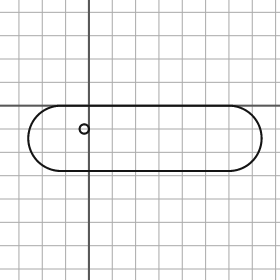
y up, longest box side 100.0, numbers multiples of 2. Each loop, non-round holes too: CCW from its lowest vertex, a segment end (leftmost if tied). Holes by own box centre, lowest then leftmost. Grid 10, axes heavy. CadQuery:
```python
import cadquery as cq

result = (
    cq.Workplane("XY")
    .moveTo(-12.0, -28.0)
    .lineTo(60.0, -28.0)
    .threePointArc((74.0, -14.0), (60.0, 0.0))
    .lineTo(-12.0, 0.0)
    .threePointArc((-26.0, -14.0), (-12.0, -28.0))
    .close()
    .moveTo(-2.0, -10.0)
    .circle(2.0)
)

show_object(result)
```